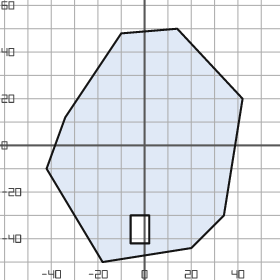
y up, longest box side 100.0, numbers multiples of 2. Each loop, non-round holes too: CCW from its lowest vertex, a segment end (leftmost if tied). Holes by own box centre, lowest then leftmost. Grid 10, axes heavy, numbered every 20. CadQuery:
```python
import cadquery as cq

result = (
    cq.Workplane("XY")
    .moveTo(-18.0, -50.0)
    .lineTo(20.0, -44.0)
    .lineTo(34.0, -30.0)
    .lineTo(42.0, 20.0)
    .lineTo(14.0, 50.0)
    .lineTo(-10.0, 48.0)
    .lineTo(-34.0, 12.0)
    .lineTo(-42.0, -10.0)
    .close()
    .moveTo(-6.0, -42.0)
    .lineTo(2.0, -42.0)
    .lineTo(2.0, -30.0)
    .lineTo(-6.0, -30.0)
    .close()
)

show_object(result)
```